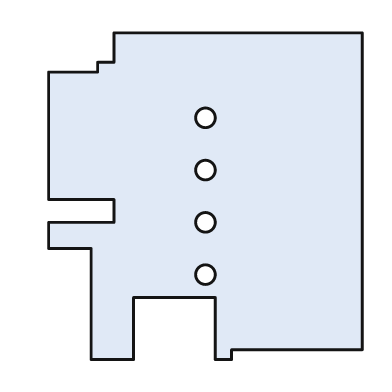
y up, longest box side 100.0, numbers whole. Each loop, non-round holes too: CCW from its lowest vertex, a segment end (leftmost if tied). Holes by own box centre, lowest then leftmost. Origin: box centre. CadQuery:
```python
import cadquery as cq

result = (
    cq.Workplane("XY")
    .moveTo(-35.0, -50.0)
    .lineTo(-22.0, -50.0)
    .lineTo(-22.0, -31.0)
    .lineTo(3.0, -31.0)
    .lineTo(3.0, -50.0)
    .lineTo(8.0, -50.0)
    .lineTo(8.0, -47.0)
    .lineTo(48.0, -47.0)
    .lineTo(48.0, 50.0)
    .lineTo(-28.0, 50.0)
    .lineTo(-28.0, 41.0)
    .lineTo(-33.0, 41.0)
    .lineTo(-33.0, 38.0)
    .lineTo(-48.0, 38.0)
    .lineTo(-48.0, -1.0)
    .lineTo(-28.0, -1.0)
    .lineTo(-28.0, -8.0)
    .lineTo(-48.0, -8.0)
    .lineTo(-48.0, -16.0)
    .lineTo(-35.0, -16.0)
    .close()
    .moveTo(0.0, -24.0)
    .circle(3.0)
    .moveTo(0.0, -8.0)
    .circle(3.0)
    .moveTo(0.0, 8.0)
    .circle(3.0)
    .moveTo(0.0, 24.0)
    .circle(3.0)
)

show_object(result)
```